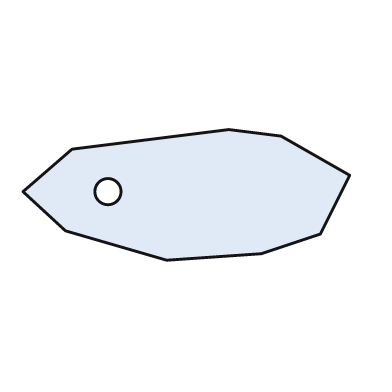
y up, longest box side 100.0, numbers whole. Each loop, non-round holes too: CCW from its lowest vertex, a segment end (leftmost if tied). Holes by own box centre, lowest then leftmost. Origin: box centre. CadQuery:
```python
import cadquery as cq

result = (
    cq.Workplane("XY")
    .moveTo(-6.0, -20.0)
    .lineTo(23.0, -18.0)
    .lineTo(41.0, -12.0)
    .lineTo(50.0, 6.0)
    .lineTo(29.0, 18.0)
    .lineTo(13.0, 20.0)
    .lineTo(-35.0, 14.0)
    .lineTo(-50.0, 1.0)
    .lineTo(-37.0, -11.0)
    .close()
    .moveTo(-24.0, 1.0)
    .circle(4.0)
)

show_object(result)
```